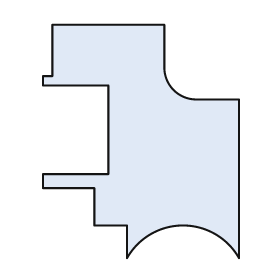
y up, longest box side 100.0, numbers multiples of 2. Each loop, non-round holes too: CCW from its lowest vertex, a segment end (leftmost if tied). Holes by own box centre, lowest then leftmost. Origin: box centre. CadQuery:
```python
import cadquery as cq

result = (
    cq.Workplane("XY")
    .moveTo(-6.0, -50.0)
    .threePointArc((18.0, -36.0), (42.0, -50.0))
    .lineTo(42.0, 18.0)
    .lineTo(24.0, 18.0)
    .threePointArc((14.0, 22.0), (10.0, 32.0))
    .lineTo(10.0, 50.0)
    .lineTo(-38.0, 50.0)
    .lineTo(-38.0, 28.0)
    .lineTo(-42.0, 28.0)
    .lineTo(-42.0, 24.0)
    .lineTo(-14.0, 24.0)
    .lineTo(-14.0, -14.0)
    .lineTo(-42.0, -14.0)
    .lineTo(-42.0, -20.0)
    .lineTo(-20.0, -20.0)
    .lineTo(-20.0, -36.0)
    .lineTo(-6.0, -36.0)
    .close()
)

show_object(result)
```